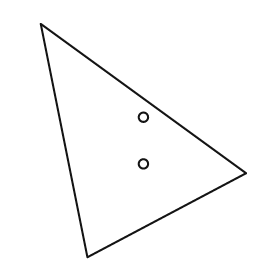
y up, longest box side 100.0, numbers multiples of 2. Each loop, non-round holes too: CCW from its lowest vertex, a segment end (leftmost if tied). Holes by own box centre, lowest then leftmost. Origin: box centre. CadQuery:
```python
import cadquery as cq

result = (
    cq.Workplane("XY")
    .moveTo(-24.0, -50.0)
    .lineTo(44.0, -14.0)
    .lineTo(-44.0, 50.0)
    .close()
    .moveTo(0.0, -10.0)
    .circle(2.0)
    .moveTo(0.0, 10.0)
    .circle(2.0)
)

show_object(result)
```